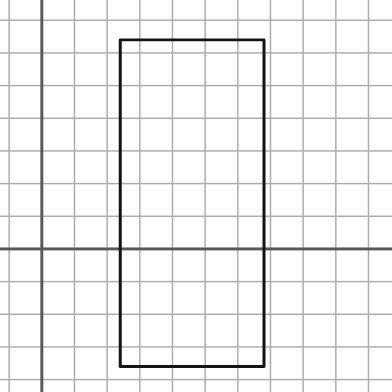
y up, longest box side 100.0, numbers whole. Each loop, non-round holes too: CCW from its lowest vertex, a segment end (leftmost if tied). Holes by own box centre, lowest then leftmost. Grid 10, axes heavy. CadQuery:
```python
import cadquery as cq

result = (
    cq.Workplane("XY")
    .moveTo(24.0, -36.0)
    .lineTo(68.0, -36.0)
    .lineTo(68.0, 64.0)
    .lineTo(24.0, 64.0)
    .close()
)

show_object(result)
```